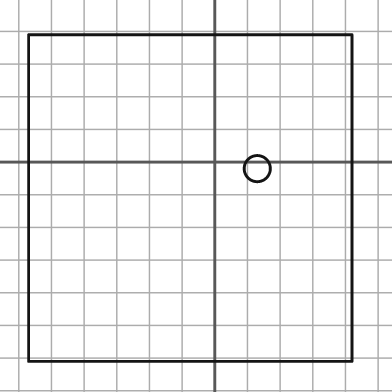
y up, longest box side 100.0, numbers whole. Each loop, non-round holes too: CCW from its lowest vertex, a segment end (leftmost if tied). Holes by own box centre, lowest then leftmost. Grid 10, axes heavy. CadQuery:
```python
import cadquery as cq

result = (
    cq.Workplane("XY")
    .moveTo(-57.0, -61.0)
    .lineTo(42.0, -61.0)
    .lineTo(42.0, 39.0)
    .lineTo(-57.0, 39.0)
    .close()
    .moveTo(13.0, -2.0)
    .circle(4.0)
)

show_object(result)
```